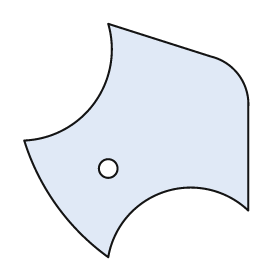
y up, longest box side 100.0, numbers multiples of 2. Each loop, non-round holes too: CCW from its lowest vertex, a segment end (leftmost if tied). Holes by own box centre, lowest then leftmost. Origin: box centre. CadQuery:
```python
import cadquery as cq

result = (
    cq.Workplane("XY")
    .moveTo(-12.0, -50.0)
    .threePointArc((12.0, -22.0), (48.0, -30.0))
    .lineTo(48.0, 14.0)
    .threePointArc((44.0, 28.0), (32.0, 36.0))
    .lineTo(-12.0, 50.0)
    .threePointArc((-18.0, 16.0), (-48.0, 0.0))
    .threePointArc((-34.0, -28.0), (-12.0, -50.0))
    .close()
    .moveTo(-12.0, -12.0)
    .circle(4.0)
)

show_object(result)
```